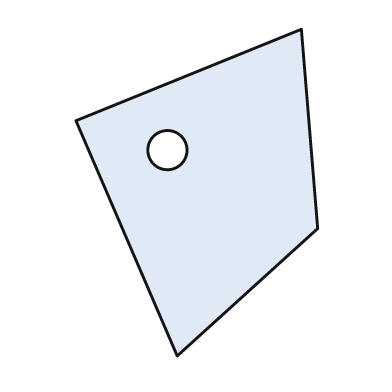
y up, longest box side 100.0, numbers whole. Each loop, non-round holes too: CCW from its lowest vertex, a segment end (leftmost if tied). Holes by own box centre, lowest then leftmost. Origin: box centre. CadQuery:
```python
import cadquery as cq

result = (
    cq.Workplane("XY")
    .moveTo(-6.0, -50.0)
    .lineTo(37.0, -11.0)
    .lineTo(32.0, 50.0)
    .lineTo(-37.0, 22.0)
    .close()
    .moveTo(-9.0, 13.0)
    .circle(6.0)
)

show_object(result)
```